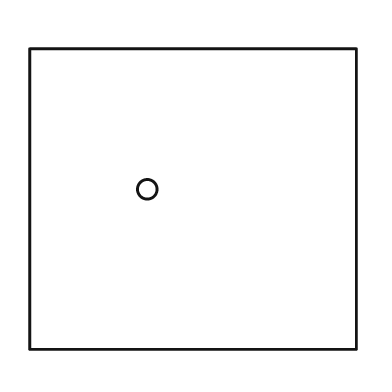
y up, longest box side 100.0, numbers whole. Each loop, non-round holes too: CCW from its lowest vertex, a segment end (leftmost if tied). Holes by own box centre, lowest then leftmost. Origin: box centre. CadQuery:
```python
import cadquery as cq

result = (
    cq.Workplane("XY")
    .moveTo(-50.0, -46.0)
    .lineTo(50.0, -46.0)
    .lineTo(50.0, 46.0)
    .lineTo(-50.0, 46.0)
    .close()
    .moveTo(-14.0, 3.0)
    .circle(3.0)
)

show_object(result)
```